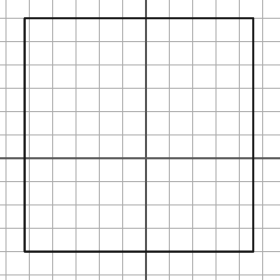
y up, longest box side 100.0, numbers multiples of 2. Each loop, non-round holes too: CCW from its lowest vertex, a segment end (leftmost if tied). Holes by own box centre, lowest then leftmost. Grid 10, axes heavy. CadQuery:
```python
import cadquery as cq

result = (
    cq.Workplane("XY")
    .moveTo(-52.0, -40.0)
    .lineTo(46.0, -40.0)
    .lineTo(46.0, 60.0)
    .lineTo(-52.0, 60.0)
    .close()
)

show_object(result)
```